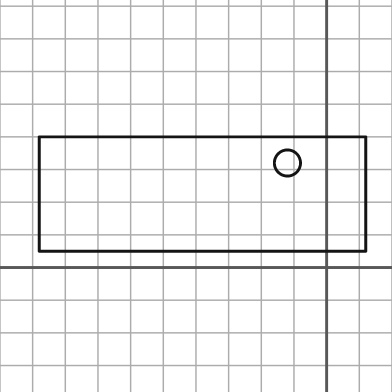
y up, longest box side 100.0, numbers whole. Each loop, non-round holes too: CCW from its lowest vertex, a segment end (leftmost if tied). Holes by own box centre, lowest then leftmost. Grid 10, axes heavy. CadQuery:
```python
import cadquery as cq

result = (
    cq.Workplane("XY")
    .moveTo(-88.0, 5.0)
    .lineTo(12.0, 5.0)
    .lineTo(12.0, 40.0)
    .lineTo(-88.0, 40.0)
    .close()
    .moveTo(-12.0, 32.0)
    .circle(4.0)
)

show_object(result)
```